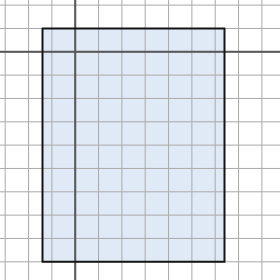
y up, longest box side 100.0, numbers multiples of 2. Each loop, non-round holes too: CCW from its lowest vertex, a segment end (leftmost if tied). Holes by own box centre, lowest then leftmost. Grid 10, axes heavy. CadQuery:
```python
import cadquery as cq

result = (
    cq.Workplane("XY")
    .moveTo(-14.0, -90.0)
    .lineTo(64.0, -90.0)
    .lineTo(64.0, 10.0)
    .lineTo(-14.0, 10.0)
    .close()
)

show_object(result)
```